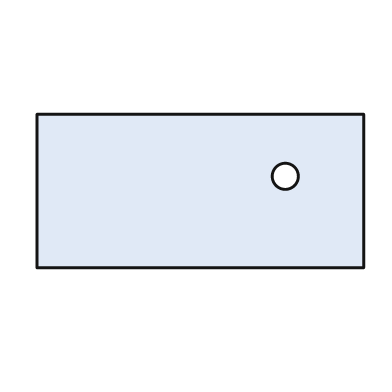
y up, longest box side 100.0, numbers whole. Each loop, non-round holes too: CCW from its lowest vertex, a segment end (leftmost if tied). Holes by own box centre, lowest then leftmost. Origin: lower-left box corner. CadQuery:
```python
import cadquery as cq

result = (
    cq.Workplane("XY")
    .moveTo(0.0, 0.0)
    .lineTo(100.0, 0.0)
    .lineTo(100.0, 47.0)
    .lineTo(0.0, 47.0)
    .close()
    .moveTo(76.0, 28.0)
    .circle(4.0)
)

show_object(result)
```